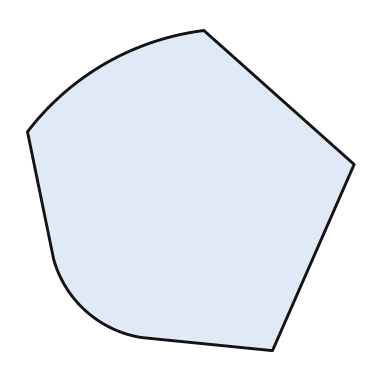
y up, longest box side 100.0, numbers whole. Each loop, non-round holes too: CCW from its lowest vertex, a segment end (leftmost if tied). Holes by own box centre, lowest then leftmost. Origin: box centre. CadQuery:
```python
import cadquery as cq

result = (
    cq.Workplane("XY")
    .moveTo(25.0, -49.0)
    .lineTo(50.0, 8.0)
    .lineTo(4.0, 49.0)
    .threePointArc((-26.0, 39.0), (-50.0, 18.0))
    .lineTo(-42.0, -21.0)
    .threePointArc((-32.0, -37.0), (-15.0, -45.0))
    .close()
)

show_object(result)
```